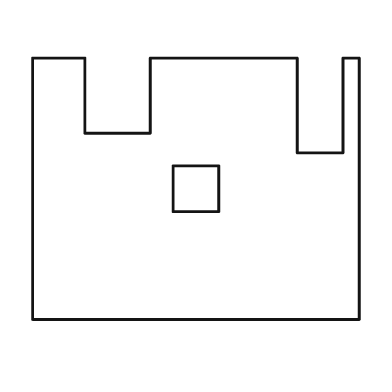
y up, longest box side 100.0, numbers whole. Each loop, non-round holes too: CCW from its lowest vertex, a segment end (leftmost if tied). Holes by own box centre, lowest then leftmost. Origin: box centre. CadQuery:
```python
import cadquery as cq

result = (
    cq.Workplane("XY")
    .moveTo(-50.0, -40.0)
    .lineTo(50.0, -40.0)
    .lineTo(50.0, 40.0)
    .lineTo(45.0, 40.0)
    .lineTo(45.0, 11.0)
    .lineTo(31.0, 11.0)
    .lineTo(31.0, 40.0)
    .lineTo(-14.0, 40.0)
    .lineTo(-14.0, 17.0)
    .lineTo(-34.0, 17.0)
    .lineTo(-34.0, 40.0)
    .lineTo(-50.0, 40.0)
    .close()
    .moveTo(-7.0, -7.0)
    .lineTo(7.0, -7.0)
    .lineTo(7.0, 7.0)
    .lineTo(-7.0, 7.0)
    .close()
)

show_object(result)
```